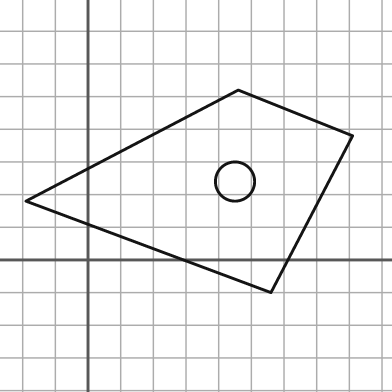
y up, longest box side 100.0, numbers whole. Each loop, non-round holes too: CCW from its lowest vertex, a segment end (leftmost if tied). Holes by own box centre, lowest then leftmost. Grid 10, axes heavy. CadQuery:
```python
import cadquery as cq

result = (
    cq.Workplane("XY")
    .moveTo(56.0, -10.0)
    .lineTo(81.0, 38.0)
    .lineTo(46.0, 52.0)
    .lineTo(-19.0, 18.0)
    .close()
    .moveTo(45.0, 24.0)
    .circle(6.0)
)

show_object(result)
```